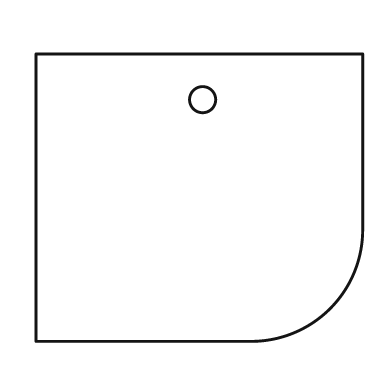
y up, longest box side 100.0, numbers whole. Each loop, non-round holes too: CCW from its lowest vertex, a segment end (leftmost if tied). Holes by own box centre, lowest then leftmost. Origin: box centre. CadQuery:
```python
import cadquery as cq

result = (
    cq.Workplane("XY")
    .moveTo(-50.0, -44.0)
    .lineTo(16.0, -44.0)
    .threePointArc((40.0, -34.0), (50.0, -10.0))
    .lineTo(50.0, 44.0)
    .lineTo(-50.0, 44.0)
    .close()
    .moveTo(1.0, 30.0)
    .circle(4.0)
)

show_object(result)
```